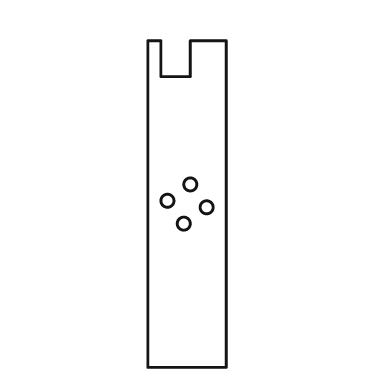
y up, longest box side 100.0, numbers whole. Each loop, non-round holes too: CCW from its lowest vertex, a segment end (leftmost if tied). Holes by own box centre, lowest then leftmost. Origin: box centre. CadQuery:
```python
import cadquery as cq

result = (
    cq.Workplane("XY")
    .moveTo(-12.0, -50.0)
    .lineTo(12.0, -50.0)
    .lineTo(12.0, 50.0)
    .lineTo(1.0, 50.0)
    .lineTo(1.0, 39.0)
    .lineTo(-8.0, 39.0)
    .lineTo(-8.0, 50.0)
    .lineTo(-12.0, 50.0)
    .close()
    .moveTo(-1.0, -6.0)
    .circle(2.0)
    .moveTo(6.0, -1.0)
    .circle(2.0)
    .moveTo(-6.0, 1.0)
    .circle(2.0)
    .moveTo(1.0, 6.0)
    .circle(2.0)
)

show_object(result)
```